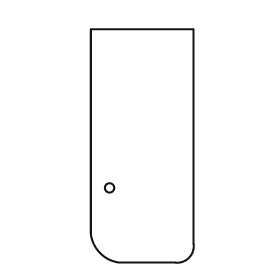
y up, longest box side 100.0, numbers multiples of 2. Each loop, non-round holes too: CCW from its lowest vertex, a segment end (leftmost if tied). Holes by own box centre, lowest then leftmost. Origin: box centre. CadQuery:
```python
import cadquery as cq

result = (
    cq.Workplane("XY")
    .moveTo(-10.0, -50.0)
    .lineTo(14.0, -50.0)
    .threePointArc((20.0, -48.0), (22.0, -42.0))
    .lineTo(22.0, 50.0)
    .lineTo(-22.0, 50.0)
    .lineTo(-22.0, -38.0)
    .threePointArc((-18.0, -46.0), (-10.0, -50.0))
    .close()
    .moveTo(-14.0, -18.0)
    .circle(2.0)
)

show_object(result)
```